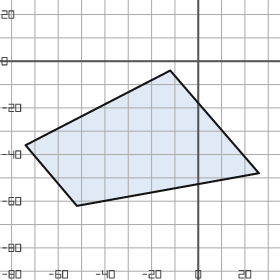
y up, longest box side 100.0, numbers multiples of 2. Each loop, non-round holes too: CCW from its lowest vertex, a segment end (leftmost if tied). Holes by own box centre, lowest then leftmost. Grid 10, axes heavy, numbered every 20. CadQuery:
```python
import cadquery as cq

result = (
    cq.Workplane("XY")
    .moveTo(-52.0, -62.0)
    .lineTo(26.0, -48.0)
    .lineTo(-12.0, -4.0)
    .lineTo(-74.0, -36.0)
    .close()
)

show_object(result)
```